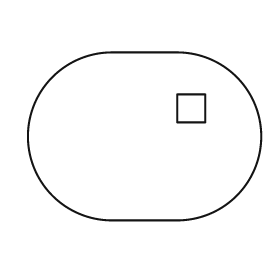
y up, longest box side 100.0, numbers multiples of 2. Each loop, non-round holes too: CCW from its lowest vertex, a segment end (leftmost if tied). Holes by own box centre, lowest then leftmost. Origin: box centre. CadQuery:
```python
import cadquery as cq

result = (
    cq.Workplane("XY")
    .moveTo(-14.0, -36.0)
    .lineTo(14.0, -36.0)
    .threePointArc((50.0, 0.0), (14.0, 36.0))
    .lineTo(-14.0, 36.0)
    .threePointArc((-50.0, 0.0), (-14.0, -36.0))
    .close()
    .moveTo(14.0, 6.0)
    .lineTo(26.0, 6.0)
    .lineTo(26.0, 18.0)
    .lineTo(14.0, 18.0)
    .close()
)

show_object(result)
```